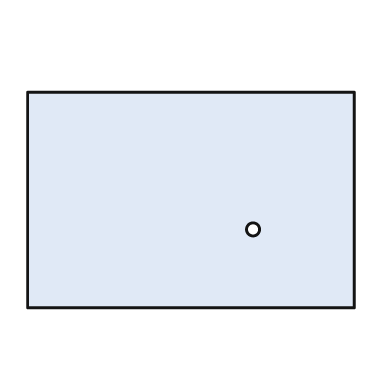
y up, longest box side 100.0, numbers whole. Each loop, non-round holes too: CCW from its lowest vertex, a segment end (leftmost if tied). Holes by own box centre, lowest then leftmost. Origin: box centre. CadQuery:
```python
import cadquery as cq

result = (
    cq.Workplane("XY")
    .moveTo(-50.0, -33.0)
    .lineTo(50.0, -33.0)
    .lineTo(50.0, 33.0)
    .lineTo(-50.0, 33.0)
    .close()
    .moveTo(19.0, -9.0)
    .circle(2.0)
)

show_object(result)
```